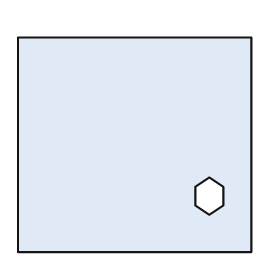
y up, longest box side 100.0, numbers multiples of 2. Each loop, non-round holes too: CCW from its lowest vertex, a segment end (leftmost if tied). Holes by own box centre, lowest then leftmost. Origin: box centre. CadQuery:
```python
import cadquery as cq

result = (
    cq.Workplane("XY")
    .moveTo(-50.0, -46.0)
    .lineTo(50.0, -46.0)
    .lineTo(50.0, 46.0)
    .lineTo(-50.0, 46.0)
    .close()
    .moveTo(32.0, -30.0)
    .lineTo(38.0, -26.0)
    .lineTo(38.0, -18.0)
    .lineTo(32.0, -14.0)
    .lineTo(26.0, -18.0)
    .lineTo(26.0, -26.0)
    .close()
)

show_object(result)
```